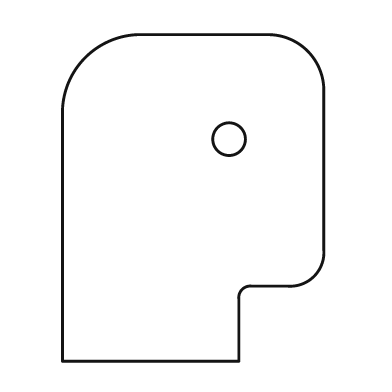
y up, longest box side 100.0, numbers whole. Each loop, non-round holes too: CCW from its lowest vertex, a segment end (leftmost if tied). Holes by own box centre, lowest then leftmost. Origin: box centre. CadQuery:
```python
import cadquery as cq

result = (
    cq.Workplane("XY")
    .moveTo(-40.0, -50.0)
    .lineTo(14.0, -50.0)
    .lineTo(14.0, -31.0)
    .threePointArc((15.0, -28.0), (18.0, -27.0))
    .lineTo(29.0, -27.0)
    .threePointArc((37.0, -24.0), (40.0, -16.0))
    .lineTo(40.0, 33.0)
    .threePointArc((35.0, 45.0), (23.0, 50.0))
    .lineTo(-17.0, 50.0)
    .threePointArc((-33.0, 43.0), (-40.0, 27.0))
    .close()
    .moveTo(11.0, 18.0)
    .circle(5.0)
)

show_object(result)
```